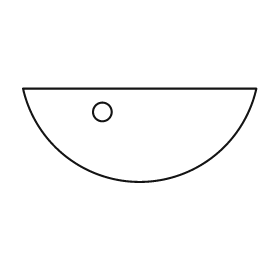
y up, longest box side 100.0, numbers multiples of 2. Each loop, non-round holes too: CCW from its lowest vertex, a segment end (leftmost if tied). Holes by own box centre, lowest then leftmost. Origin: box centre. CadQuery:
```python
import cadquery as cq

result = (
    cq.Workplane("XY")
    .moveTo(-50.0, 20.0)
    .threePointArc((0.0, -20.0), (50.0, 20.0))
    .close()
    .moveTo(-16.0, 10.0)
    .circle(4.0)
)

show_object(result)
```